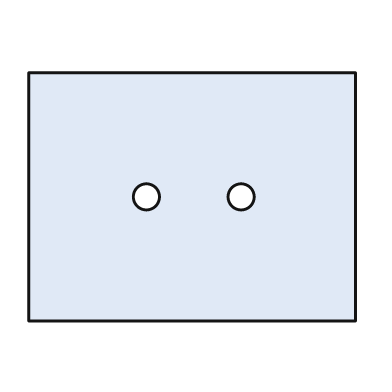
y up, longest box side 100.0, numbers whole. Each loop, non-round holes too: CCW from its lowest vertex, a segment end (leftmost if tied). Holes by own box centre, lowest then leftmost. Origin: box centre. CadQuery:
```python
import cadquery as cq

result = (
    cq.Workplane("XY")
    .moveTo(-50.0, -38.0)
    .lineTo(50.0, -38.0)
    .lineTo(50.0, 38.0)
    .lineTo(-50.0, 38.0)
    .close()
    .moveTo(-14.0, 0.0)
    .circle(4.0)
    .moveTo(15.0, 0.0)
    .circle(4.0)
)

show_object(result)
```